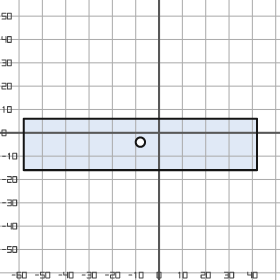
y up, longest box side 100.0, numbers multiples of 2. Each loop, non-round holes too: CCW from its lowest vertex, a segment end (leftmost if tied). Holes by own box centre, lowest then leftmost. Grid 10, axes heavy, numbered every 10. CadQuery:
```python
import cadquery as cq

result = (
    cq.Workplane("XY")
    .moveTo(-58.0, -16.0)
    .lineTo(42.0, -16.0)
    .lineTo(42.0, 6.0)
    .lineTo(-58.0, 6.0)
    .close()
    .moveTo(-8.0, -4.0)
    .circle(2.0)
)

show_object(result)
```